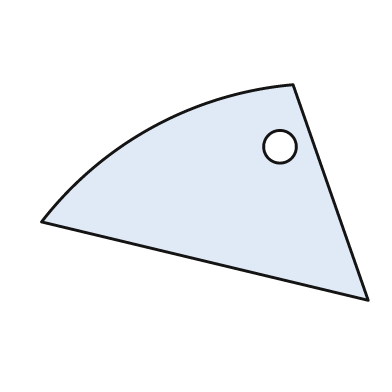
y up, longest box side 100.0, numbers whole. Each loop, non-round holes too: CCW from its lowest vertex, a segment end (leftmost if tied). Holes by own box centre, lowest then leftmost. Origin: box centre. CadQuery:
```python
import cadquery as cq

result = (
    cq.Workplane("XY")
    .moveTo(50.0, -33.0)
    .lineTo(27.0, 33.0)
    .threePointArc((-16.0, 20.0), (-50.0, -9.0))
    .close()
    .moveTo(23.0, 14.0)
    .circle(5.0)
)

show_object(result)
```